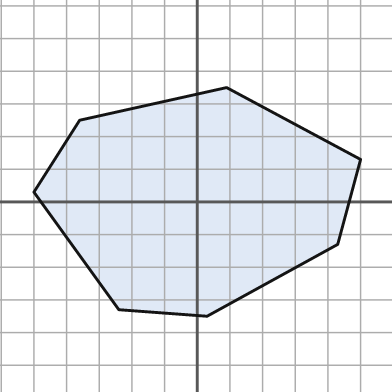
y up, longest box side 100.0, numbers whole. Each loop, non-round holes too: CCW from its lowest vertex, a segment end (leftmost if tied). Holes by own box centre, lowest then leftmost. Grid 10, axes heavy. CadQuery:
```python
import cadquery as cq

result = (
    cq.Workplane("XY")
    .moveTo(3.0, -35.0)
    .lineTo(43.0, -13.0)
    .lineTo(50.0, 13.0)
    .lineTo(9.0, 35.0)
    .lineTo(-36.0, 25.0)
    .lineTo(-50.0, 3.0)
    .lineTo(-24.0, -33.0)
    .close()
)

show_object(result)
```